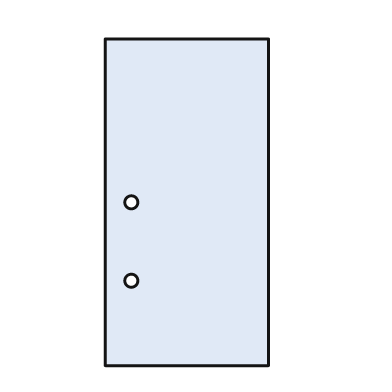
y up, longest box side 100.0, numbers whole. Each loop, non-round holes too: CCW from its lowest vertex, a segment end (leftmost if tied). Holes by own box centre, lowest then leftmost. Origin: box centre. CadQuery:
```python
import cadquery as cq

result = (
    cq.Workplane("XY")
    .moveTo(-25.0, -50.0)
    .lineTo(25.0, -50.0)
    .lineTo(25.0, 50.0)
    .lineTo(-25.0, 50.0)
    .close()
    .moveTo(-17.0, -24.0)
    .circle(2.0)
    .moveTo(-17.0, 0.0)
    .circle(2.0)
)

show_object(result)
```